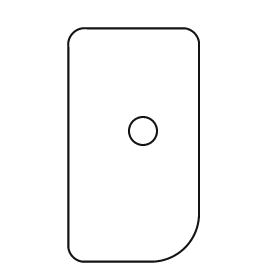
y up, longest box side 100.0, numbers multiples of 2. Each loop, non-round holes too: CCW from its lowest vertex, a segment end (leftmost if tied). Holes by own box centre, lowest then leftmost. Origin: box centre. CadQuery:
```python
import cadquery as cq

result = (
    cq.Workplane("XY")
    .moveTo(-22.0, -50.0)
    .lineTo(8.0, -50.0)
    .threePointArc((22.0, -44.0), (28.0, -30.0))
    .lineTo(28.0, 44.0)
    .threePointArc((26.0, 48.0), (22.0, 50.0))
    .lineTo(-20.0, 50.0)
    .threePointArc((-26.0, 48.0), (-28.0, 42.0))
    .lineTo(-28.0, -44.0)
    .threePointArc((-26.0, -48.0), (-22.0, -50.0))
    .close()
    .moveTo(4.0, 6.0)
    .circle(6.0)
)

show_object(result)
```